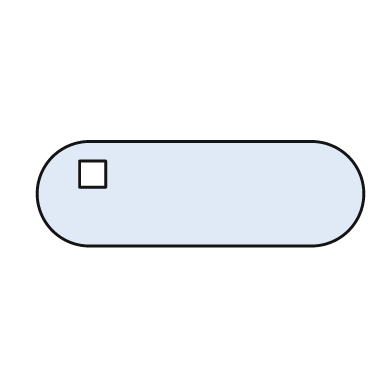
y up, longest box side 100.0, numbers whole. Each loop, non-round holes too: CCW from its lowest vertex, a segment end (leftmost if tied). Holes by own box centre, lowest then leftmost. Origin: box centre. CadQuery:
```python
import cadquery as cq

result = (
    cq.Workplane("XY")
    .moveTo(-34.0, -16.0)
    .lineTo(34.0, -16.0)
    .threePointArc((50.0, 0.0), (34.0, 16.0))
    .lineTo(-34.0, 16.0)
    .threePointArc((-50.0, 0.0), (-34.0, -16.0))
    .close()
    .moveTo(-37.0, 2.0)
    .lineTo(-29.0, 2.0)
    .lineTo(-29.0, 10.0)
    .lineTo(-37.0, 10.0)
    .close()
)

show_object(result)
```